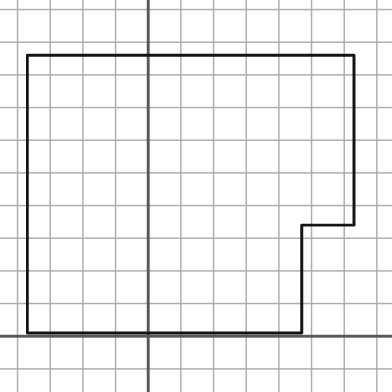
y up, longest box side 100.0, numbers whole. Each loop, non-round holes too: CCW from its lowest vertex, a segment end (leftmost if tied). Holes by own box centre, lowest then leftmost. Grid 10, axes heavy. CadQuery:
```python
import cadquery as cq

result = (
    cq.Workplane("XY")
    .moveTo(-37.0, 1.0)
    .lineTo(47.0, 1.0)
    .lineTo(47.0, 34.0)
    .lineTo(63.0, 34.0)
    .lineTo(63.0, 86.0)
    .lineTo(-37.0, 86.0)
    .close()
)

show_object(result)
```